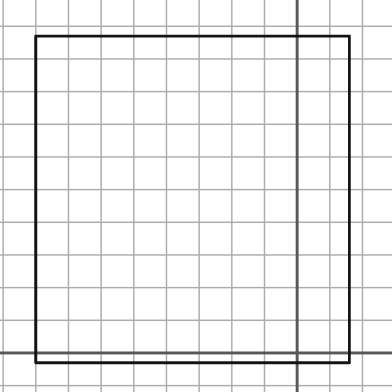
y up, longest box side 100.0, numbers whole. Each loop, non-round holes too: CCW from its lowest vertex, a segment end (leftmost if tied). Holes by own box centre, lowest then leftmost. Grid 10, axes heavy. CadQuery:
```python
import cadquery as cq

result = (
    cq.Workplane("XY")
    .moveTo(-80.0, -3.0)
    .lineTo(16.0, -3.0)
    .lineTo(16.0, 97.0)
    .lineTo(-80.0, 97.0)
    .close()
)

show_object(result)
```